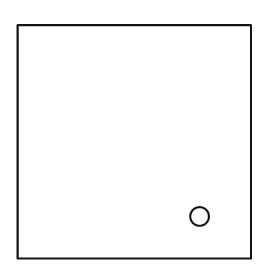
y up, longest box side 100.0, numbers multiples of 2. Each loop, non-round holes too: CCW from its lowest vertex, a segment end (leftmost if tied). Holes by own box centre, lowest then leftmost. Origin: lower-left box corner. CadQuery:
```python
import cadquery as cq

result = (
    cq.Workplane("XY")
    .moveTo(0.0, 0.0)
    .lineTo(100.0, 0.0)
    .lineTo(100.0, 100.0)
    .lineTo(0.0, 100.0)
    .close()
    .moveTo(78.0, 18.0)
    .circle(4.0)
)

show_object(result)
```